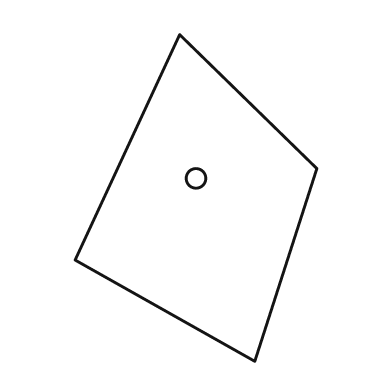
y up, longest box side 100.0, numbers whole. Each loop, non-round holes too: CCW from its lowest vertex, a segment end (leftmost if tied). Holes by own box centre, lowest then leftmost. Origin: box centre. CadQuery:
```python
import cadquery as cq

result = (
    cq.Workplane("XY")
    .moveTo(18.0, -50.0)
    .lineTo(37.0, 9.0)
    .lineTo(-5.0, 50.0)
    .lineTo(-37.0, -19.0)
    .close()
    .moveTo(0.0, 6.0)
    .circle(3.0)
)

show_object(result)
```